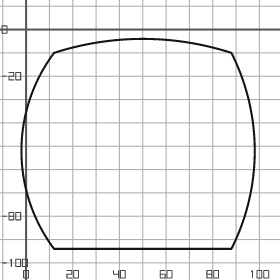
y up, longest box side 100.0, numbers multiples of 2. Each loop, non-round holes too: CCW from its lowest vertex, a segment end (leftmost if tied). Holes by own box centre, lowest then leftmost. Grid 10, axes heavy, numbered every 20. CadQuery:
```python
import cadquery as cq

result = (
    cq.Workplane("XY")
    .moveTo(12.0, -94.0)
    .lineTo(88.0, -94.0)
    .threePointArc((98.0, -52.0), (88.0, -10.0))
    .threePointArc((50.0, -4.0), (12.0, -10.0))
    .threePointArc((-2.0, -52.0), (12.0, -94.0))
    .close()
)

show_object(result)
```